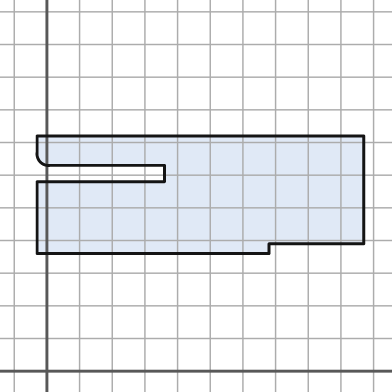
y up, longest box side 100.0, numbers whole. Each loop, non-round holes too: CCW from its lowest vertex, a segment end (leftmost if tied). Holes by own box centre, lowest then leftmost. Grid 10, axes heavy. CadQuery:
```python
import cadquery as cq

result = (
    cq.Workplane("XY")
    .moveTo(-3.0, 36.0)
    .lineTo(68.0, 36.0)
    .lineTo(68.0, 39.0)
    .lineTo(97.0, 39.0)
    .lineTo(97.0, 72.0)
    .lineTo(-3.0, 72.0)
    .lineTo(-3.0, 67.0)
    .threePointArc((-2.0, 64.0), (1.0, 63.0))
    .lineTo(36.0, 63.0)
    .lineTo(36.0, 58.0)
    .lineTo(-3.0, 58.0)
    .close()
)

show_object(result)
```